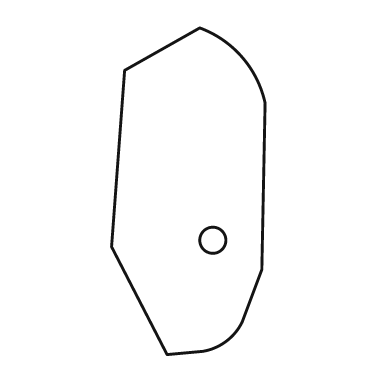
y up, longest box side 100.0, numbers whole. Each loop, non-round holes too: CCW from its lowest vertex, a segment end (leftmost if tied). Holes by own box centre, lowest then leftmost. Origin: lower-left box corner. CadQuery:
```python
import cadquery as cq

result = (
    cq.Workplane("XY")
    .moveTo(17.0, 0.0)
    .lineTo(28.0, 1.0)
    .threePointArc((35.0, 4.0), (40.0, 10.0))
    .lineTo(46.0, 26.0)
    .lineTo(47.0, 77.0)
    .threePointArc((40.0, 91.0), (27.0, 100.0))
    .lineTo(4.0, 87.0)
    .lineTo(0.0, 33.0)
    .close()
    .moveTo(31.0, 35.0)
    .circle(4.0)
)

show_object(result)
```